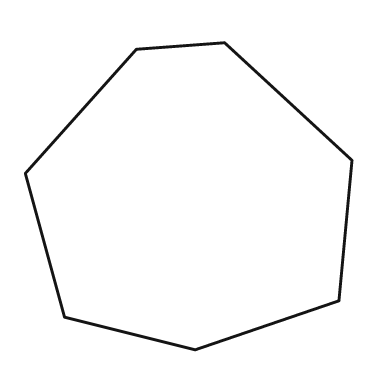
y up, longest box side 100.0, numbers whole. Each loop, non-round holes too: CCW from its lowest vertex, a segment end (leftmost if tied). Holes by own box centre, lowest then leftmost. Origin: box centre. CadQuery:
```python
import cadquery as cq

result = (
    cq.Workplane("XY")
    .moveTo(2.0, -47.0)
    .lineTo(46.0, -32.0)
    .lineTo(50.0, 11.0)
    .lineTo(11.0, 47.0)
    .lineTo(-16.0, 45.0)
    .lineTo(-50.0, 7.0)
    .lineTo(-38.0, -37.0)
    .close()
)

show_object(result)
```